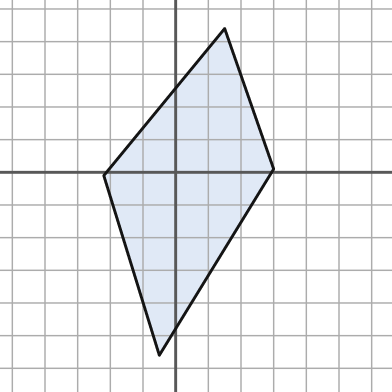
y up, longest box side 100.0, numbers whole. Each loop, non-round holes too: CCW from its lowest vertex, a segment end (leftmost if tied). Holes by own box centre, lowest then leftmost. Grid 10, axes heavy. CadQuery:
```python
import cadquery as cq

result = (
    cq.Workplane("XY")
    .moveTo(-5.0, -56.0)
    .lineTo(30.0, 1.0)
    .lineTo(15.0, 44.0)
    .lineTo(-22.0, -1.0)
    .close()
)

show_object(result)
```